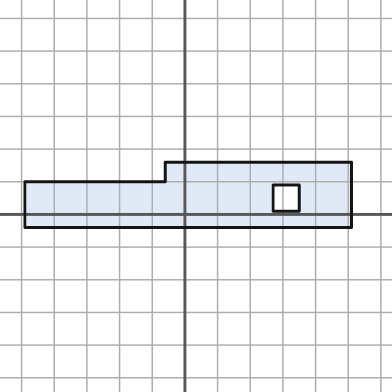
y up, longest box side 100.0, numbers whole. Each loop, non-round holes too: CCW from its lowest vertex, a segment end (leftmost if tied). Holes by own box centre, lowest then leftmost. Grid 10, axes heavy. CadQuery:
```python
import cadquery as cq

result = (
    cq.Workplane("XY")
    .moveTo(-49.0, -4.0)
    .lineTo(51.0, -4.0)
    .lineTo(51.0, 16.0)
    .lineTo(-6.0, 16.0)
    .lineTo(-6.0, 10.0)
    .lineTo(-49.0, 10.0)
    .close()
    .moveTo(27.0, 1.0)
    .lineTo(35.0, 1.0)
    .lineTo(35.0, 9.0)
    .lineTo(27.0, 9.0)
    .close()
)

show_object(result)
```